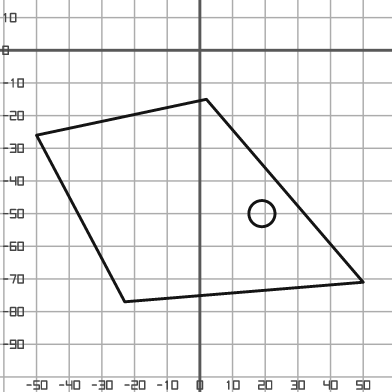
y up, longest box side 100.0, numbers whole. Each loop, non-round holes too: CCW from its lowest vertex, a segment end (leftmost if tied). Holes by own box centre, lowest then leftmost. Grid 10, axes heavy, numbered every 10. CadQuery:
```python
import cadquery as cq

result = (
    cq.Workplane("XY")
    .moveTo(-23.0, -77.0)
    .lineTo(50.0, -71.0)
    .lineTo(2.0, -15.0)
    .lineTo(-50.0, -26.0)
    .close()
    .moveTo(19.0, -50.0)
    .circle(4.0)
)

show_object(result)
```